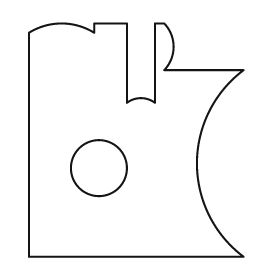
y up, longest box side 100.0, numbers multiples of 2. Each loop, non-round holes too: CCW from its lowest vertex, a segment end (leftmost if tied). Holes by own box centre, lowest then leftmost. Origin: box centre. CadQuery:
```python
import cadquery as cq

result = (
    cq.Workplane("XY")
    .moveTo(-46.0, -50.0)
    .lineTo(46.0, -50.0)
    .threePointArc((26.0, -10.0), (46.0, 30.0))
    .lineTo(12.0, 30.0)
    .threePointArc((16.0, 40.0), (12.0, 50.0))
    .lineTo(8.0, 50.0)
    .lineTo(8.0, 16.0)
    .threePointArc((2.0, 18.0), (-4.0, 16.0))
    .lineTo(-4.0, 50.0)
    .lineTo(-18.0, 50.0)
    .lineTo(-18.0, 46.0)
    .threePointArc((-32.0, 50.0), (-46.0, 46.0))
    .close()
    .moveTo(-16.0, -12.0)
    .circle(12.0)
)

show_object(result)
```